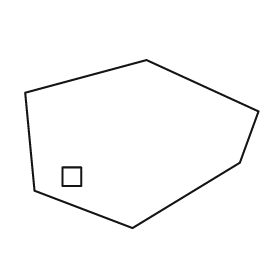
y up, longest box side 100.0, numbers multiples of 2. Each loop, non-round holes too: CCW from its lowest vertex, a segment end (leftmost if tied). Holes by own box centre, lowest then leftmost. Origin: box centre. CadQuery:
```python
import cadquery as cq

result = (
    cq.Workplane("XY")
    .moveTo(-4.0, -36.0)
    .lineTo(42.0, -8.0)
    .lineTo(50.0, 14.0)
    .lineTo(2.0, 36.0)
    .lineTo(-50.0, 22.0)
    .lineTo(-46.0, -20.0)
    .close()
    .moveTo(-34.0, -18.0)
    .lineTo(-26.0, -18.0)
    .lineTo(-26.0, -10.0)
    .lineTo(-34.0, -10.0)
    .close()
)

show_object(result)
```